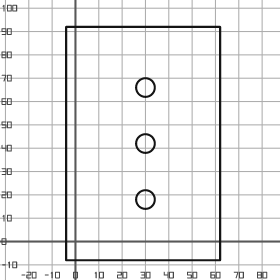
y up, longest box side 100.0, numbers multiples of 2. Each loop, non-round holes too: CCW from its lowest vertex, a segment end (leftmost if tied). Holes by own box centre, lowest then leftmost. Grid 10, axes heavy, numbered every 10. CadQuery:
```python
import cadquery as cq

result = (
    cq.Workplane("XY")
    .moveTo(-4.0, -8.0)
    .lineTo(62.0, -8.0)
    .lineTo(62.0, 92.0)
    .lineTo(-4.0, 92.0)
    .close()
    .moveTo(30.0, 18.0)
    .circle(4.0)
    .moveTo(30.0, 42.0)
    .circle(4.0)
    .moveTo(30.0, 66.0)
    .circle(4.0)
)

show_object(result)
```